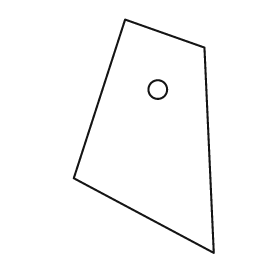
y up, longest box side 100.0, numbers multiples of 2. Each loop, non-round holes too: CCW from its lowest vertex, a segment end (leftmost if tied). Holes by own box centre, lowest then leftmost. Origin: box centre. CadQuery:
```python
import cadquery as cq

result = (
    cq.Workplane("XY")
    .moveTo(30.0, -50.0)
    .lineTo(26.0, 38.0)
    .lineTo(-8.0, 50.0)
    .lineTo(-30.0, -18.0)
    .close()
    .moveTo(6.0, 20.0)
    .circle(4.0)
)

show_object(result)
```